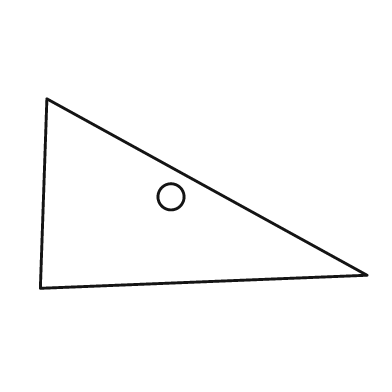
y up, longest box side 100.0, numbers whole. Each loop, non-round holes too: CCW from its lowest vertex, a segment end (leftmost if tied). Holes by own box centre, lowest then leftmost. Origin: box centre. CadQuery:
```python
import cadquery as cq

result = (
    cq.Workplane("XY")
    .moveTo(-50.0, -29.0)
    .lineTo(50.0, -25.0)
    .lineTo(-48.0, 29.0)
    .close()
    .moveTo(-10.0, -1.0)
    .circle(4.0)
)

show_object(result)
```